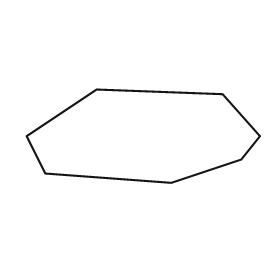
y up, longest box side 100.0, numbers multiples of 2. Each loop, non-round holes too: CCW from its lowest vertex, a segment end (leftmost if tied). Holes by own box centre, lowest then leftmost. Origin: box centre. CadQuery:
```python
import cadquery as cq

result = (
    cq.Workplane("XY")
    .moveTo(12.0, -20.0)
    .lineTo(42.0, -10.0)
    .lineTo(50.0, 0.0)
    .lineTo(34.0, 18.0)
    .lineTo(-20.0, 20.0)
    .lineTo(-50.0, 0.0)
    .lineTo(-42.0, -16.0)
    .close()
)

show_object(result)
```